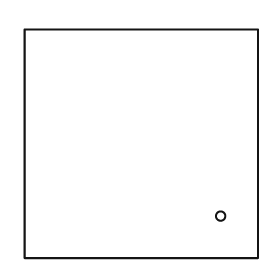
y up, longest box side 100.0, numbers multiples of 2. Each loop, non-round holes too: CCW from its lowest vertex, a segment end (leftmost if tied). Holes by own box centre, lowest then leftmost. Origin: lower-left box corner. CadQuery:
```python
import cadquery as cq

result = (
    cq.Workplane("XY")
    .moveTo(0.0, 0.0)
    .lineTo(100.0, 0.0)
    .lineTo(100.0, 98.0)
    .lineTo(0.0, 98.0)
    .close()
    .moveTo(84.0, 18.0)
    .circle(2.0)
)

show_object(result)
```